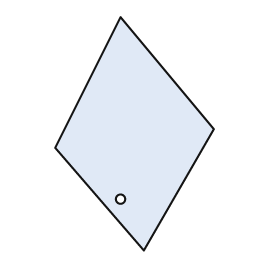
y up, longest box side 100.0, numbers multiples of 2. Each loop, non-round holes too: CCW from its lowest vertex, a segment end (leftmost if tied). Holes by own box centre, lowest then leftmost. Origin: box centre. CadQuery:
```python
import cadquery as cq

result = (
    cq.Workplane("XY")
    .moveTo(4.0, -50.0)
    .lineTo(34.0, 2.0)
    .lineTo(-6.0, 50.0)
    .lineTo(-34.0, -6.0)
    .close()
    .moveTo(-6.0, -28.0)
    .circle(2.0)
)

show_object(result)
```